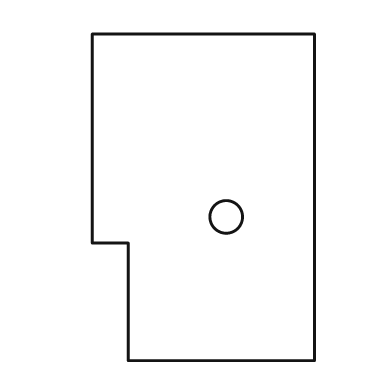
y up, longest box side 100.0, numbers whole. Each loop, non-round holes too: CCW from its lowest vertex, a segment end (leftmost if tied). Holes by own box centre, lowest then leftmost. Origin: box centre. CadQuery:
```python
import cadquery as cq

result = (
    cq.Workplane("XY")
    .moveTo(-23.0, -50.0)
    .lineTo(34.0, -50.0)
    .lineTo(34.0, 50.0)
    .lineTo(-34.0, 50.0)
    .lineTo(-34.0, -14.0)
    .lineTo(-23.0, -14.0)
    .close()
    .moveTo(7.0, -6.0)
    .circle(5.0)
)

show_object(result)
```